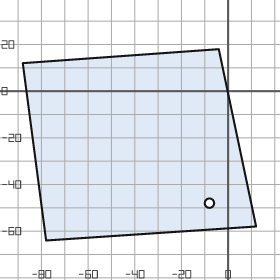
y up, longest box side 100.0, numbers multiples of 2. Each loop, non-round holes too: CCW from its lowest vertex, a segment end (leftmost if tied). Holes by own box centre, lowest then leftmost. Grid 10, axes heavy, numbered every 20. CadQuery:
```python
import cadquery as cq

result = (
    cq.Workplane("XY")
    .moveTo(-78.0, -64.0)
    .lineTo(12.0, -58.0)
    .lineTo(-4.0, 18.0)
    .lineTo(-88.0, 12.0)
    .close()
    .moveTo(-8.0, -48.0)
    .circle(2.0)
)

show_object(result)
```